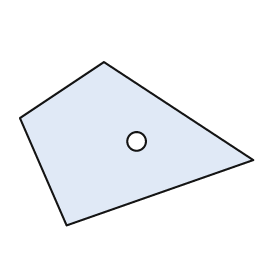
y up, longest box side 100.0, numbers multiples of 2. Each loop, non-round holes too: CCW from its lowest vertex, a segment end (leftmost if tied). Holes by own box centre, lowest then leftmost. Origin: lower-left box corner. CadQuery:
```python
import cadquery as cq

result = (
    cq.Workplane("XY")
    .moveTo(20.0, 0.0)
    .lineTo(100.0, 28.0)
    .lineTo(36.0, 70.0)
    .lineTo(0.0, 46.0)
    .close()
    .moveTo(50.0, 36.0)
    .circle(4.0)
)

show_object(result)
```